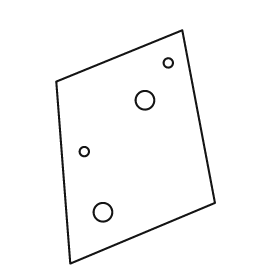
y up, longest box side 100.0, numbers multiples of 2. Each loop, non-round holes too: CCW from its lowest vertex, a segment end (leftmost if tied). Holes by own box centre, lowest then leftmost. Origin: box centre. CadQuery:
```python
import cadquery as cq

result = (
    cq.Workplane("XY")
    .moveTo(-28.0, -50.0)
    .lineTo(34.0, -24.0)
    .lineTo(20.0, 50.0)
    .lineTo(-34.0, 28.0)
    .close()
    .moveTo(-14.0, -28.0)
    .circle(4.0)
    .moveTo(-22.0, -2.0)
    .circle(2.0)
    .moveTo(4.0, 20.0)
    .circle(4.0)
    .moveTo(14.0, 36.0)
    .circle(2.0)
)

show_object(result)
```